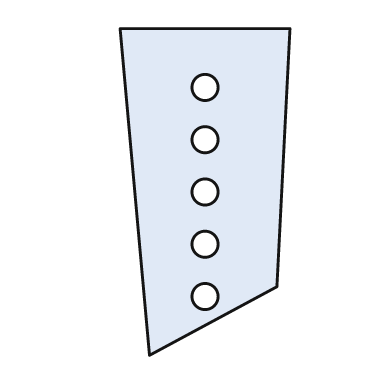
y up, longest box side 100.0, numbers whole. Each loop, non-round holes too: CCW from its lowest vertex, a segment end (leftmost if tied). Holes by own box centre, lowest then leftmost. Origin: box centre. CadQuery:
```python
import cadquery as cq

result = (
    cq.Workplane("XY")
    .moveTo(-17.0, -50.0)
    .lineTo(22.0, -29.0)
    .lineTo(26.0, 50.0)
    .lineTo(-26.0, 50.0)
    .close()
    .moveTo(0.0, -32.0)
    .circle(4.0)
    .moveTo(0.0, -16.0)
    .circle(4.0)
    .moveTo(0.0, 0.0)
    .circle(4.0)
    .moveTo(0.0, 16.0)
    .circle(4.0)
    .moveTo(0.0, 32.0)
    .circle(4.0)
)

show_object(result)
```